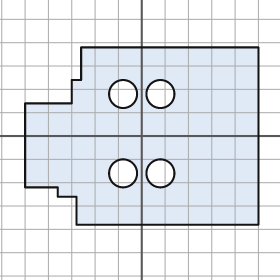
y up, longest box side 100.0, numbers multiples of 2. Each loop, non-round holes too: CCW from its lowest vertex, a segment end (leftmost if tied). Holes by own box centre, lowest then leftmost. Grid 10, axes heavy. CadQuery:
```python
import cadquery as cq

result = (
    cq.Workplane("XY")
    .moveTo(-28.0, -38.0)
    .lineTo(50.0, -38.0)
    .lineTo(50.0, 38.0)
    .lineTo(-26.0, 38.0)
    .lineTo(-26.0, 24.0)
    .lineTo(-30.0, 24.0)
    .lineTo(-30.0, 14.0)
    .lineTo(-50.0, 14.0)
    .lineTo(-50.0, -22.0)
    .lineTo(-36.0, -22.0)
    .lineTo(-36.0, -26.0)
    .lineTo(-28.0, -26.0)
    .close()
    .moveTo(-8.0, -16.0)
    .circle(6.0)
    .moveTo(8.0, -16.0)
    .circle(6.0)
    .moveTo(-8.0, 18.0)
    .circle(6.0)
    .moveTo(8.0, 18.0)
    .circle(6.0)
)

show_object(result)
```